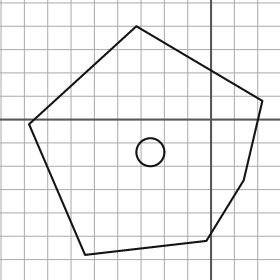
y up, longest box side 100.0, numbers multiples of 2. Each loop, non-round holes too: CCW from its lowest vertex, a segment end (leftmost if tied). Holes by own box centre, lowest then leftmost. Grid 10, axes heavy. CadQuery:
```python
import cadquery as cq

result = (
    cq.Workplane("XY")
    .moveTo(-54.0, -58.0)
    .lineTo(-2.0, -52.0)
    .lineTo(14.0, -26.0)
    .lineTo(22.0, 8.0)
    .lineTo(-32.0, 40.0)
    .lineTo(-78.0, -2.0)
    .close()
    .moveTo(-26.0, -14.0)
    .circle(6.0)
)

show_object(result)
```